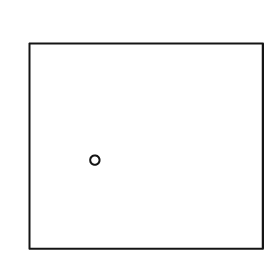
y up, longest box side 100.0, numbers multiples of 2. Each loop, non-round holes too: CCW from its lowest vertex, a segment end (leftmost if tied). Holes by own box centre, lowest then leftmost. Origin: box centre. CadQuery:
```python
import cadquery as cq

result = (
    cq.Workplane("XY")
    .moveTo(-50.0, -44.0)
    .lineTo(50.0, -44.0)
    .lineTo(50.0, 44.0)
    .lineTo(-50.0, 44.0)
    .close()
    .moveTo(-22.0, -6.0)
    .circle(2.0)
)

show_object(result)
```